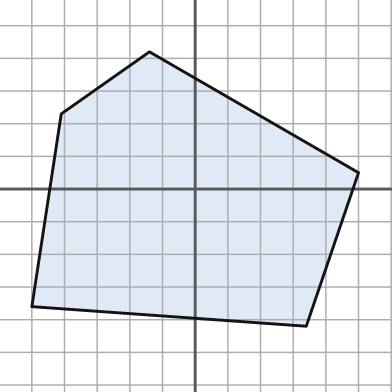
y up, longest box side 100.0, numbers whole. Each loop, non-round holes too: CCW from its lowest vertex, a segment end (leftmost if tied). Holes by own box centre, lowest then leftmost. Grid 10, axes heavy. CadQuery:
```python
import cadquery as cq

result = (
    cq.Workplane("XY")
    .moveTo(34.0, -42.0)
    .lineTo(50.0, 5.0)
    .lineTo(-14.0, 42.0)
    .lineTo(-41.0, 23.0)
    .lineTo(-50.0, -36.0)
    .close()
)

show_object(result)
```